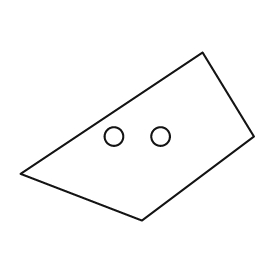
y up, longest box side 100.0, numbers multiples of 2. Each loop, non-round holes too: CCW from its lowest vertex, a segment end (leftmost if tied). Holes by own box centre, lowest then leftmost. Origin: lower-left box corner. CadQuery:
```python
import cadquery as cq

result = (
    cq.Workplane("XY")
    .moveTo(52.0, 0.0)
    .lineTo(100.0, 36.0)
    .lineTo(78.0, 72.0)
    .lineTo(0.0, 20.0)
    .close()
    .moveTo(40.0, 36.0)
    .circle(4.0)
    .moveTo(60.0, 36.0)
    .circle(4.0)
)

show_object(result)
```